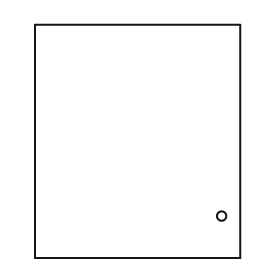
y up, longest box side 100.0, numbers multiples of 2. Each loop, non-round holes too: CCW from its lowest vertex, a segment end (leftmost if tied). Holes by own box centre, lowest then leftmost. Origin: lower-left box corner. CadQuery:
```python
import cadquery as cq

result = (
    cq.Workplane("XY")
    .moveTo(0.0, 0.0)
    .lineTo(88.0, 0.0)
    .lineTo(88.0, 100.0)
    .lineTo(0.0, 100.0)
    .close()
    .moveTo(80.0, 18.0)
    .circle(2.0)
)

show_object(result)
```